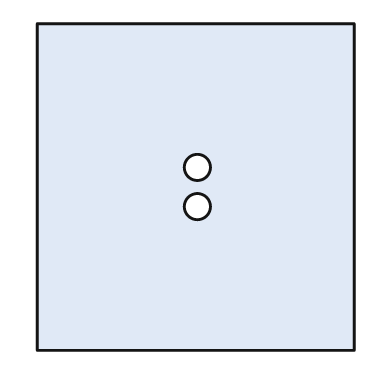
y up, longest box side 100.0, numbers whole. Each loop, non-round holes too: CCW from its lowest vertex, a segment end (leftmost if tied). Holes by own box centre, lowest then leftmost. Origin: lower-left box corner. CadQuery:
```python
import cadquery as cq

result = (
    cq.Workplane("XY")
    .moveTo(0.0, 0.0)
    .lineTo(97.0, 0.0)
    .lineTo(97.0, 100.0)
    .lineTo(0.0, 100.0)
    .close()
    .moveTo(49.0, 44.0)
    .circle(4.0)
    .moveTo(49.0, 56.0)
    .circle(4.0)
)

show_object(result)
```